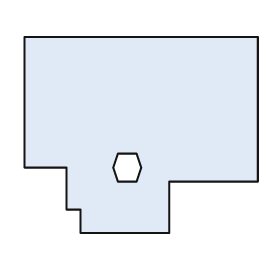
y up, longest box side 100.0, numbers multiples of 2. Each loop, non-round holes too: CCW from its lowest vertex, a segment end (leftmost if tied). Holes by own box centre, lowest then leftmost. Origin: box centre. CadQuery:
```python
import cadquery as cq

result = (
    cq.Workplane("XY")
    .moveTo(-26.0, -42.0)
    .lineTo(12.0, -42.0)
    .lineTo(12.0, -20.0)
    .lineTo(50.0, -20.0)
    .lineTo(50.0, 42.0)
    .lineTo(-50.0, 42.0)
    .lineTo(-50.0, -14.0)
    .lineTo(-32.0, -14.0)
    .lineTo(-32.0, -32.0)
    .lineTo(-26.0, -32.0)
    .close()
    .moveTo(-10.0, -20.0)
    .lineTo(-2.0, -20.0)
    .lineTo(0.0, -14.0)
    .lineTo(-2.0, -8.0)
    .lineTo(-10.0, -8.0)
    .lineTo(-12.0, -14.0)
    .close()
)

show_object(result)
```